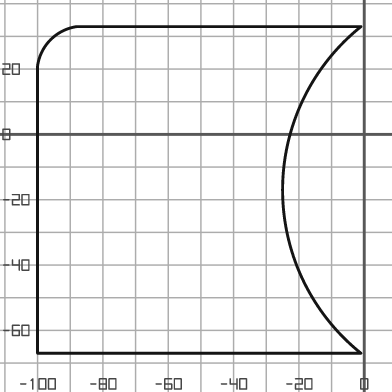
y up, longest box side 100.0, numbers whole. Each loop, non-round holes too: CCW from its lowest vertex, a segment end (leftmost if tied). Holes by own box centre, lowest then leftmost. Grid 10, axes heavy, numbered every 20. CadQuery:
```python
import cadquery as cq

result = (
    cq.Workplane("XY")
    .moveTo(-100.0, -67.0)
    .lineTo(-1.0, -67.0)
    .threePointArc((-25.0, -17.0), (-1.0, 33.0))
    .lineTo(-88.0, 33.0)
    .threePointArc((-96.0, 29.0), (-100.0, 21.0))
    .close()
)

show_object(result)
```